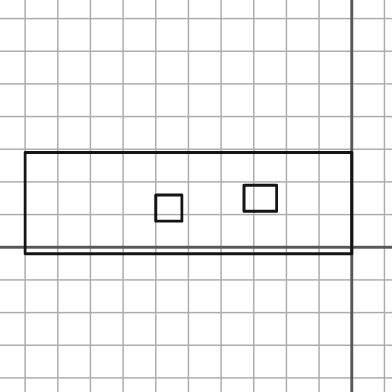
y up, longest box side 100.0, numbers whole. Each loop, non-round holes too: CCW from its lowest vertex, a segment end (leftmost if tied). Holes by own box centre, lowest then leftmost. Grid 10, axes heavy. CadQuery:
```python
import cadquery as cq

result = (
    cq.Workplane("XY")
    .moveTo(-100.0, -2.0)
    .lineTo(0.0, -2.0)
    .lineTo(0.0, 29.0)
    .lineTo(-100.0, 29.0)
    .close()
    .moveTo(-60.0, 8.0)
    .lineTo(-52.0, 8.0)
    .lineTo(-52.0, 16.0)
    .lineTo(-60.0, 16.0)
    .close()
    .moveTo(-33.0, 11.0)
    .lineTo(-23.0, 11.0)
    .lineTo(-23.0, 19.0)
    .lineTo(-33.0, 19.0)
    .close()
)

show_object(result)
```